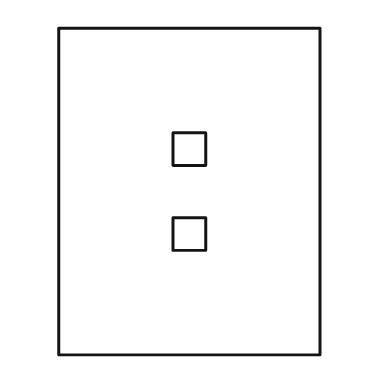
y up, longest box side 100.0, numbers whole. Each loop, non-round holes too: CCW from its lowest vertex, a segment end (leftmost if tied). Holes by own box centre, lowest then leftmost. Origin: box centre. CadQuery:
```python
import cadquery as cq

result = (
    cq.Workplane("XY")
    .moveTo(-40.0, -50.0)
    .lineTo(40.0, -50.0)
    .lineTo(40.0, 50.0)
    .lineTo(-40.0, 50.0)
    .close()
    .moveTo(-5.0, -18.0)
    .lineTo(5.0, -18.0)
    .lineTo(5.0, -8.0)
    .lineTo(-5.0, -8.0)
    .close()
    .moveTo(-5.0, 8.0)
    .lineTo(5.0, 8.0)
    .lineTo(5.0, 18.0)
    .lineTo(-5.0, 18.0)
    .close()
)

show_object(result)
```